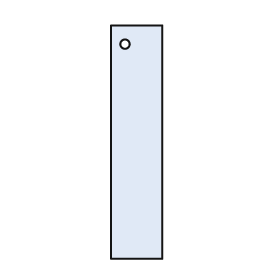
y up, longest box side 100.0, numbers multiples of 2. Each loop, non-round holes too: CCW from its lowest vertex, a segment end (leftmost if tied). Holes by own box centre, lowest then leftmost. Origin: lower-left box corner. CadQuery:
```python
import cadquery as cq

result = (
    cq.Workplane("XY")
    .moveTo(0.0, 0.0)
    .lineTo(22.0, 0.0)
    .lineTo(22.0, 100.0)
    .lineTo(0.0, 100.0)
    .close()
    .moveTo(6.0, 92.0)
    .circle(2.0)
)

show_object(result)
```